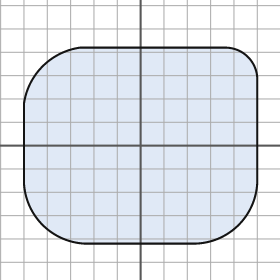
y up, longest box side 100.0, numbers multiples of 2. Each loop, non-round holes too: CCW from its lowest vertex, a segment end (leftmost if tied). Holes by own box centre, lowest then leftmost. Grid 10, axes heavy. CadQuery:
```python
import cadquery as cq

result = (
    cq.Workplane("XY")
    .moveTo(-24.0, -42.0)
    .lineTo(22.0, -42.0)
    .threePointArc((42.0, -34.0), (50.0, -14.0))
    .lineTo(50.0, 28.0)
    .threePointArc((46.0, 38.0), (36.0, 42.0))
    .lineTo(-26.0, 42.0)
    .threePointArc((-42.0, 34.0), (-50.0, 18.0))
    .lineTo(-50.0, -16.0)
    .threePointArc((-42.0, -34.0), (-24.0, -42.0))
    .close()
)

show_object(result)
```